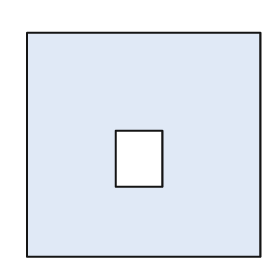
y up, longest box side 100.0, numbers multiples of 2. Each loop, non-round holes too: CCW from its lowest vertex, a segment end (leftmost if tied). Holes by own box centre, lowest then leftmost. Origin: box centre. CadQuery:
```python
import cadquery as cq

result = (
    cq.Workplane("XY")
    .moveTo(-50.0, -48.0)
    .lineTo(50.0, -48.0)
    .lineTo(50.0, 48.0)
    .lineTo(-50.0, 48.0)
    .close()
    .moveTo(-12.0, -18.0)
    .lineTo(8.0, -18.0)
    .lineTo(8.0, 6.0)
    .lineTo(-12.0, 6.0)
    .close()
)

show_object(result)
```